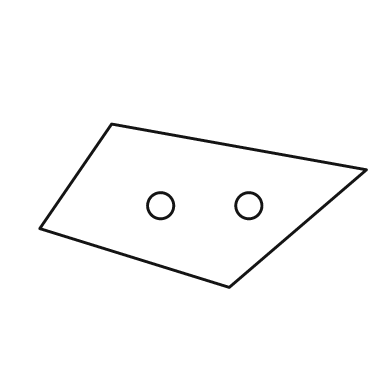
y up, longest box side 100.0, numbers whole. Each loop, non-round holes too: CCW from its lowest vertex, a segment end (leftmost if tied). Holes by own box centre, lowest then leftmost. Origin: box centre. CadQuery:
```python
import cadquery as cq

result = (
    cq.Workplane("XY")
    .moveTo(8.0, -25.0)
    .lineTo(50.0, 11.0)
    .lineTo(-28.0, 25.0)
    .lineTo(-50.0, -7.0)
    .close()
    .moveTo(-13.0, 0.0)
    .circle(4.0)
    .moveTo(14.0, 0.0)
    .circle(4.0)
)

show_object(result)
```